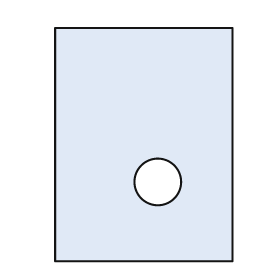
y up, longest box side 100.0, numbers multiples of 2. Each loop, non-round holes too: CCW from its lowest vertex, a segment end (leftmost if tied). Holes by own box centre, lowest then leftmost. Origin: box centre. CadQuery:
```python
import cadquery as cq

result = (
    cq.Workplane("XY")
    .moveTo(-38.0, -50.0)
    .lineTo(38.0, -50.0)
    .lineTo(38.0, 50.0)
    .lineTo(-38.0, 50.0)
    .close()
    .moveTo(6.0, -16.0)
    .circle(10.0)
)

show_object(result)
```